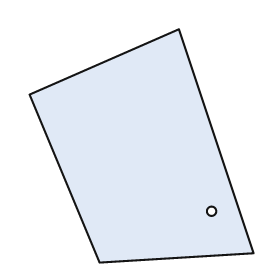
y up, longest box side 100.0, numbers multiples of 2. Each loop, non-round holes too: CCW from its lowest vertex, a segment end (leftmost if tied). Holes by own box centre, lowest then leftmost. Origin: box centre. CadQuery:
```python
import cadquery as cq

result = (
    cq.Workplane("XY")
    .moveTo(-18.0, -50.0)
    .lineTo(48.0, -46.0)
    .lineTo(16.0, 50.0)
    .lineTo(-48.0, 22.0)
    .close()
    .moveTo(30.0, -28.0)
    .circle(2.0)
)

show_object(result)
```